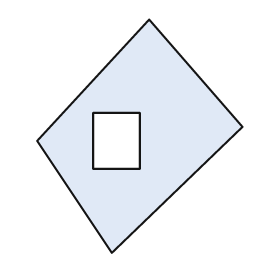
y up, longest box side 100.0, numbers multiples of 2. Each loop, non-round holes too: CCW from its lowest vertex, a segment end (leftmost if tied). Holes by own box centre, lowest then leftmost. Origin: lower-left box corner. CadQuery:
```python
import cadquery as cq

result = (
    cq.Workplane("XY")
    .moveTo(32.0, 0.0)
    .lineTo(88.0, 54.0)
    .lineTo(48.0, 100.0)
    .lineTo(0.0, 48.0)
    .close()
    .moveTo(24.0, 36.0)
    .lineTo(44.0, 36.0)
    .lineTo(44.0, 60.0)
    .lineTo(24.0, 60.0)
    .close()
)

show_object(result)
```